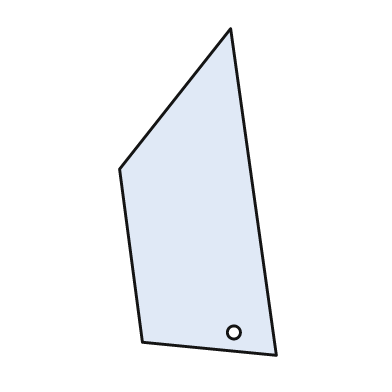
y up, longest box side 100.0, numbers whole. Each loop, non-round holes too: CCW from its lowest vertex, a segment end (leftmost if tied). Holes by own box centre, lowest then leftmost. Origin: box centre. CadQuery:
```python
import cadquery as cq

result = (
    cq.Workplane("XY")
    .moveTo(24.0, -50.0)
    .lineTo(10.0, 50.0)
    .lineTo(-24.0, 7.0)
    .lineTo(-17.0, -46.0)
    .close()
    .moveTo(11.0, -43.0)
    .circle(2.0)
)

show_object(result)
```